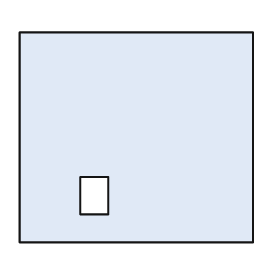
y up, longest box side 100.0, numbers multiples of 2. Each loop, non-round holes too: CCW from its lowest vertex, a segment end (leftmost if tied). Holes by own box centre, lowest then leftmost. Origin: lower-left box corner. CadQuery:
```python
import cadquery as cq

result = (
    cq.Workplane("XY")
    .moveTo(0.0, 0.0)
    .lineTo(100.0, 0.0)
    .lineTo(100.0, 90.0)
    .lineTo(0.0, 90.0)
    .close()
    .moveTo(26.0, 12.0)
    .lineTo(38.0, 12.0)
    .lineTo(38.0, 28.0)
    .lineTo(26.0, 28.0)
    .close()
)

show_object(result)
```